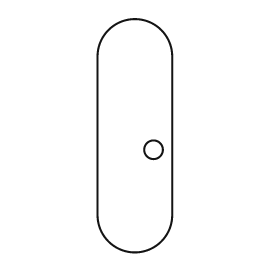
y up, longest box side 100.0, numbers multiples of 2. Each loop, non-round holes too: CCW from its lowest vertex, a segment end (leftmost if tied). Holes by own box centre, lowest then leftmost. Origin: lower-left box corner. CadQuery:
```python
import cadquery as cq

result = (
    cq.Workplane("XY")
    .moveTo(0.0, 16.0)
    .threePointArc((16.0, 0.0), (32.0, 16.0))
    .lineTo(32.0, 84.0)
    .threePointArc((16.0, 100.0), (0.0, 84.0))
    .close()
    .moveTo(24.0, 44.0)
    .circle(4.0)
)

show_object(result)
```